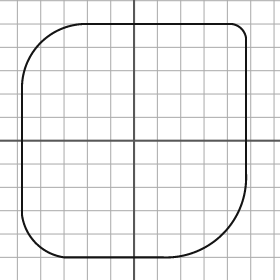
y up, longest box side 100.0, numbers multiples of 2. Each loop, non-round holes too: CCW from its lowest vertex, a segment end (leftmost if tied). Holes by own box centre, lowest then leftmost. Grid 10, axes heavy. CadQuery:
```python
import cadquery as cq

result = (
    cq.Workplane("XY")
    .moveTo(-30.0, -50.0)
    .lineTo(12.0, -50.0)
    .threePointArc((38.0, -40.0), (48.0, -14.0))
    .lineTo(48.0, 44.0)
    .threePointArc((46.0, 48.0), (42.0, 50.0))
    .lineTo(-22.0, 50.0)
    .threePointArc((-40.0, 42.0), (-48.0, 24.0))
    .lineTo(-48.0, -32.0)
    .threePointArc((-42.0, -44.0), (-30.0, -50.0))
    .close()
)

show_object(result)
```